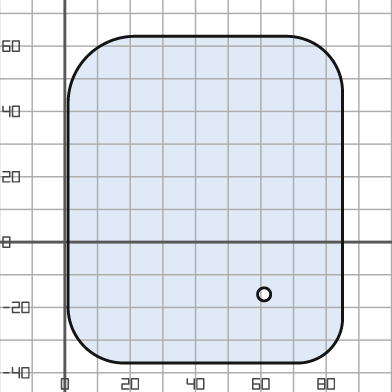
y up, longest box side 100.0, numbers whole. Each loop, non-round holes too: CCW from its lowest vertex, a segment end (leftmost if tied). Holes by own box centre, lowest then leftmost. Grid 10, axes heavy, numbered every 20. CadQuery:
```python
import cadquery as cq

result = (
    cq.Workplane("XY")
    .moveTo(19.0, -37.0)
    .lineTo(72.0, -37.0)
    .threePointArc((81.0, -33.0), (85.0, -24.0))
    .lineTo(85.0, 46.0)
    .threePointArc((80.0, 58.0), (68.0, 63.0))
    .lineTo(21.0, 63.0)
    .threePointArc((7.0, 57.0), (1.0, 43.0))
    .lineTo(1.0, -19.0)
    .threePointArc((6.0, -32.0), (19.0, -37.0))
    .close()
    .moveTo(61.0, -16.0)
    .circle(2.0)
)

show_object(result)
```